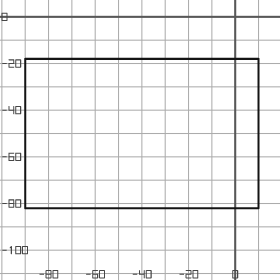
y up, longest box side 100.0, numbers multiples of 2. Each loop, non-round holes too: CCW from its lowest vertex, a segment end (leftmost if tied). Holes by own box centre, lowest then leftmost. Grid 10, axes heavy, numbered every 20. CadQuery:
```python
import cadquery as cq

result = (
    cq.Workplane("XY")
    .moveTo(-90.0, -82.0)
    .lineTo(10.0, -82.0)
    .lineTo(10.0, -18.0)
    .lineTo(-90.0, -18.0)
    .close()
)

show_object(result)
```